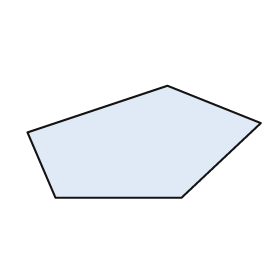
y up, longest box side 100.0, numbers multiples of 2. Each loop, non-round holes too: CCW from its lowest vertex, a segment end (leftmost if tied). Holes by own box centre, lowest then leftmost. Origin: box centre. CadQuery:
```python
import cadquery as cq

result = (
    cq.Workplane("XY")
    .moveTo(-38.0, -24.0)
    .lineTo(16.0, -24.0)
    .lineTo(50.0, 8.0)
    .lineTo(10.0, 24.0)
    .lineTo(-50.0, 4.0)
    .close()
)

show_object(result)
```